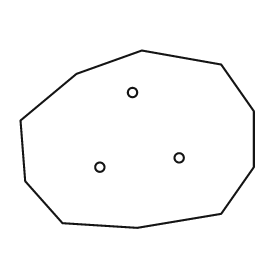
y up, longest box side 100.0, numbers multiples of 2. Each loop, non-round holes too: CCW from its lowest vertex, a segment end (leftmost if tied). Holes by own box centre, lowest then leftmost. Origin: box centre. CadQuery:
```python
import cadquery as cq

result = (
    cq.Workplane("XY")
    .moveTo(0.0, -38.0)
    .lineTo(36.0, -32.0)
    .lineTo(50.0, -12.0)
    .lineTo(50.0, 12.0)
    .lineTo(36.0, 32.0)
    .lineTo(2.0, 38.0)
    .lineTo(-26.0, 28.0)
    .lineTo(-50.0, 8.0)
    .lineTo(-48.0, -18.0)
    .lineTo(-32.0, -36.0)
    .close()
    .moveTo(-16.0, -12.0)
    .circle(2.0)
    .moveTo(18.0, -8.0)
    .circle(2.0)
    .moveTo(-2.0, 20.0)
    .circle(2.0)
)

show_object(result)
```